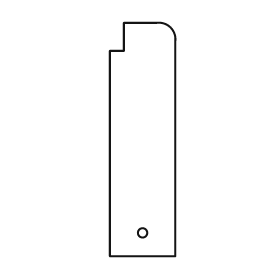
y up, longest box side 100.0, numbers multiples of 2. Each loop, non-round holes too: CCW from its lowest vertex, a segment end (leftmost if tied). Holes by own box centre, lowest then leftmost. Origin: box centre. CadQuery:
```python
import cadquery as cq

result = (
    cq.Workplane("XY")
    .moveTo(-14.0, -50.0)
    .lineTo(14.0, -50.0)
    .lineTo(14.0, 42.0)
    .threePointArc((12.0, 48.0), (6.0, 50.0))
    .lineTo(-8.0, 50.0)
    .lineTo(-8.0, 38.0)
    .lineTo(-14.0, 38.0)
    .close()
    .moveTo(0.0, -40.0)
    .circle(2.0)
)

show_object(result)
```